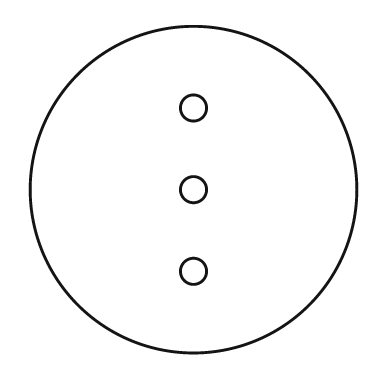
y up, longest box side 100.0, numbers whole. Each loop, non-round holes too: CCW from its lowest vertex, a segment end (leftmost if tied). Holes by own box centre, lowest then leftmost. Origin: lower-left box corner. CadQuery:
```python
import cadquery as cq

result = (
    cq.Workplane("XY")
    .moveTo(50.0, 50.0)
    .circle(50.0)
    .moveTo(50.0, 25.0)
    .circle(4.0)
    .moveTo(50.0, 50.0)
    .circle(4.0)
    .moveTo(50.0, 75.0)
    .circle(4.0)
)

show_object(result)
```